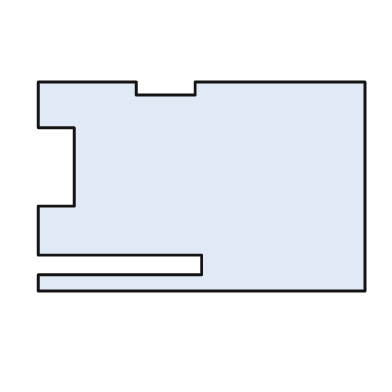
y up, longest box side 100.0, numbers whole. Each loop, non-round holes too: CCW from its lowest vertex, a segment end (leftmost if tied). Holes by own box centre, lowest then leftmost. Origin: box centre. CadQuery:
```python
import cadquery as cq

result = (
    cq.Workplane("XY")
    .moveTo(-50.0, -32.0)
    .lineTo(50.0, -32.0)
    .lineTo(50.0, 32.0)
    .lineTo(-2.0, 32.0)
    .lineTo(-2.0, 28.0)
    .lineTo(-20.0, 28.0)
    .lineTo(-20.0, 32.0)
    .lineTo(-50.0, 32.0)
    .lineTo(-50.0, 18.0)
    .lineTo(-39.0, 18.0)
    .lineTo(-39.0, -6.0)
    .lineTo(-50.0, -6.0)
    .lineTo(-50.0, -21.0)
    .lineTo(0.0, -21.0)
    .lineTo(0.0, -27.0)
    .lineTo(-50.0, -27.0)
    .close()
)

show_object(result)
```